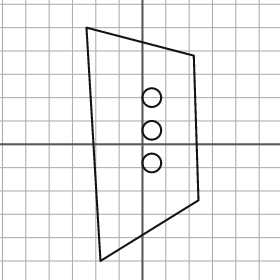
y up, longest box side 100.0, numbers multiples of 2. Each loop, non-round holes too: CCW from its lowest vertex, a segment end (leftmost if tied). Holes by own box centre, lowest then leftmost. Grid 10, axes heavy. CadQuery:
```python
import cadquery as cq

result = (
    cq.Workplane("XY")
    .moveTo(-18.0, -50.0)
    .lineTo(24.0, -24.0)
    .lineTo(22.0, 38.0)
    .lineTo(-24.0, 50.0)
    .close()
    .moveTo(4.0, -8.0)
    .circle(4.0)
    .moveTo(4.0, 6.0)
    .circle(4.0)
    .moveTo(4.0, 20.0)
    .circle(4.0)
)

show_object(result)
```